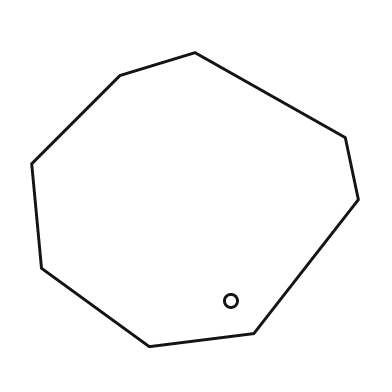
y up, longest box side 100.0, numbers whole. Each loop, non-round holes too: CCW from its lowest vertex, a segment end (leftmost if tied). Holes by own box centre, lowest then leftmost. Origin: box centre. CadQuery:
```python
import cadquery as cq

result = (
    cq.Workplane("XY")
    .moveTo(-14.0, -45.0)
    .lineTo(18.0, -41.0)
    .lineTo(50.0, 0.0)
    .lineTo(46.0, 19.0)
    .lineTo(0.0, 45.0)
    .lineTo(-23.0, 38.0)
    .lineTo(-50.0, 11.0)
    .lineTo(-47.0, -21.0)
    .close()
    .moveTo(11.0, -31.0)
    .circle(2.0)
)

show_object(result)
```